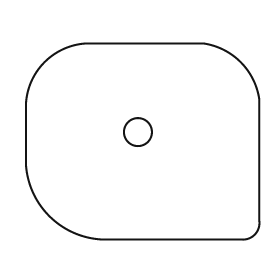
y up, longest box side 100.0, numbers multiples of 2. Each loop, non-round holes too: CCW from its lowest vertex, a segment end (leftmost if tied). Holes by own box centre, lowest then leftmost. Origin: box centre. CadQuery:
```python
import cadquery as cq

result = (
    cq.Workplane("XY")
    .moveTo(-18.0, -42.0)
    .lineTo(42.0, -42.0)
    .threePointArc((48.0, -40.0), (50.0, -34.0))
    .lineTo(50.0, 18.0)
    .threePointArc((42.0, 34.0), (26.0, 42.0))
    .lineTo(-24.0, 42.0)
    .threePointArc((-42.0, 34.0), (-50.0, 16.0))
    .lineTo(-50.0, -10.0)
    .threePointArc((-40.0, -32.0), (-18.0, -42.0))
    .close()
    .moveTo(-2.0, 4.0)
    .circle(6.0)
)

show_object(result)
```